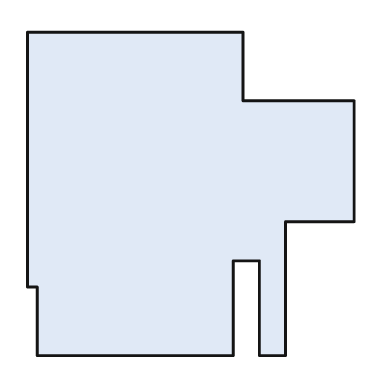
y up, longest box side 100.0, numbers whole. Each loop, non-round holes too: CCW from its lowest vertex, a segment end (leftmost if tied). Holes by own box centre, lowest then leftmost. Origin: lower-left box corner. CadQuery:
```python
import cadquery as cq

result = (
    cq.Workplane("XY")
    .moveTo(3.0, 0.0)
    .lineTo(63.0, 0.0)
    .lineTo(63.0, 29.0)
    .lineTo(71.0, 29.0)
    .lineTo(71.0, 0.0)
    .lineTo(79.0, 0.0)
    .lineTo(79.0, 41.0)
    .lineTo(100.0, 41.0)
    .lineTo(100.0, 78.0)
    .lineTo(66.0, 78.0)
    .lineTo(66.0, 99.0)
    .lineTo(0.0, 99.0)
    .lineTo(0.0, 21.0)
    .lineTo(3.0, 21.0)
    .close()
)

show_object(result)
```